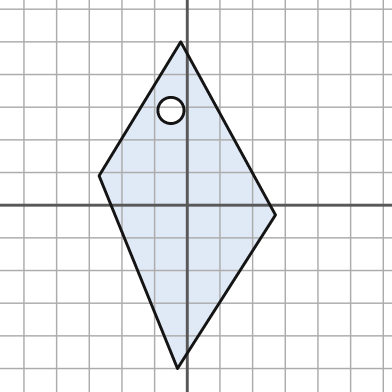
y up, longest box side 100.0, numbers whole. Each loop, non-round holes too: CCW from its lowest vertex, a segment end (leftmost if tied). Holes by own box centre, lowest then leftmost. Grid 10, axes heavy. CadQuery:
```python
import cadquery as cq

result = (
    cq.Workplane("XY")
    .moveTo(-3.0, -50.0)
    .lineTo(27.0, -3.0)
    .lineTo(-2.0, 50.0)
    .lineTo(-27.0, 9.0)
    .close()
    .moveTo(-5.0, 29.0)
    .circle(4.0)
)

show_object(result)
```